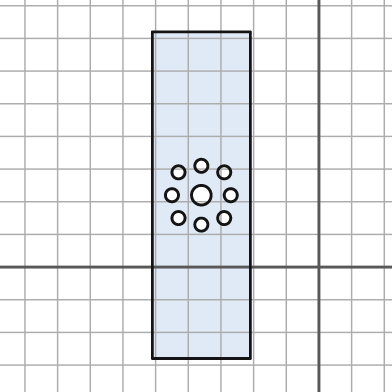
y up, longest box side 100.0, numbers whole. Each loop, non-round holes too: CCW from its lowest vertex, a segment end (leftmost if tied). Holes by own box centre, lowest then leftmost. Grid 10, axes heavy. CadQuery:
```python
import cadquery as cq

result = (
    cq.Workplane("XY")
    .moveTo(-51.0, -28.0)
    .lineTo(-21.0, -28.0)
    .lineTo(-21.0, 72.0)
    .lineTo(-51.0, 72.0)
    .close()
    .moveTo(-36.0, 13.0)
    .circle(2.0)
    .moveTo(-43.0, 15.0)
    .circle(2.0)
    .moveTo(-29.0, 15.0)
    .circle(2.0)
    .moveTo(-45.0, 22.0)
    .circle(2.0)
    .moveTo(-36.0, 22.0)
    .circle(3.0)
    .moveTo(-27.0, 22.0)
    .circle(2.0)
    .moveTo(-43.0, 29.0)
    .circle(2.0)
    .moveTo(-29.0, 29.0)
    .circle(2.0)
    .moveTo(-36.0, 31.0)
    .circle(2.0)
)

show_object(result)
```